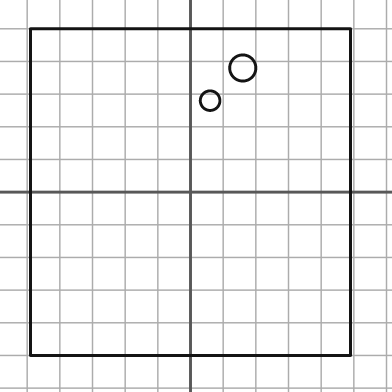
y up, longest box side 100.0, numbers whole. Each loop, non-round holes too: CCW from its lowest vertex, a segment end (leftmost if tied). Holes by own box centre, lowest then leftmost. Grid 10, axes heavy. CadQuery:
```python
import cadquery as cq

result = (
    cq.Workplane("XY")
    .moveTo(-49.0, -50.0)
    .lineTo(49.0, -50.0)
    .lineTo(49.0, 50.0)
    .lineTo(-49.0, 50.0)
    .close()
    .moveTo(6.0, 28.0)
    .circle(3.0)
    .moveTo(16.0, 38.0)
    .circle(4.0)
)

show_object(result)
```